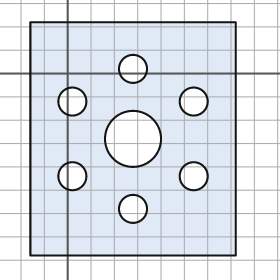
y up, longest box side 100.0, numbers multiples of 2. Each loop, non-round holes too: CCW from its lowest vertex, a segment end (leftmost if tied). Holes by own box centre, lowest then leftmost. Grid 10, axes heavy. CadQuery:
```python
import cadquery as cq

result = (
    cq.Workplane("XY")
    .moveTo(-16.0, -78.0)
    .lineTo(72.0, -78.0)
    .lineTo(72.0, 22.0)
    .lineTo(-16.0, 22.0)
    .close()
    .moveTo(28.0, -58.0)
    .circle(6.0)
    .moveTo(2.0, -44.0)
    .circle(6.0)
    .moveTo(54.0, -44.0)
    .circle(6.0)
    .moveTo(28.0, -28.0)
    .circle(12.0)
    .moveTo(2.0, -12.0)
    .circle(6.0)
    .moveTo(54.0, -12.0)
    .circle(6.0)
    .moveTo(28.0, 2.0)
    .circle(6.0)
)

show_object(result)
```